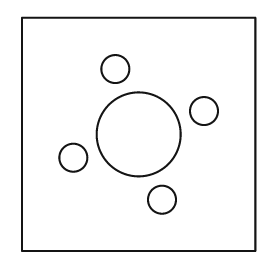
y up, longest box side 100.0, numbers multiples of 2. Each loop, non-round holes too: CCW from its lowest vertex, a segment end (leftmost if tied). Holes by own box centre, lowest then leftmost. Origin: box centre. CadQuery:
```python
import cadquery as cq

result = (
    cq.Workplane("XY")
    .moveTo(-50.0, -50.0)
    .lineTo(50.0, -50.0)
    .lineTo(50.0, 50.0)
    .lineTo(-50.0, 50.0)
    .close()
    .moveTo(10.0, -28.0)
    .circle(6.0)
    .moveTo(-28.0, -10.0)
    .circle(6.0)
    .moveTo(0.0, 0.0)
    .circle(18.0)
    .moveTo(28.0, 10.0)
    .circle(6.0)
    .moveTo(-10.0, 28.0)
    .circle(6.0)
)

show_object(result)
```